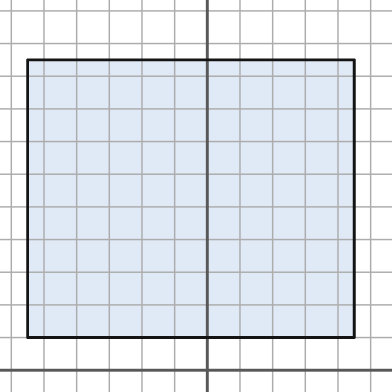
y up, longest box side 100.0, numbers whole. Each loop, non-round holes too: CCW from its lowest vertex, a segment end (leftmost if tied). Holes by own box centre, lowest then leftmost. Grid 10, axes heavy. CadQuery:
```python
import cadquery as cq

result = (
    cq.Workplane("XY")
    .moveTo(-55.0, 10.0)
    .lineTo(45.0, 10.0)
    .lineTo(45.0, 95.0)
    .lineTo(-55.0, 95.0)
    .close()
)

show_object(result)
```